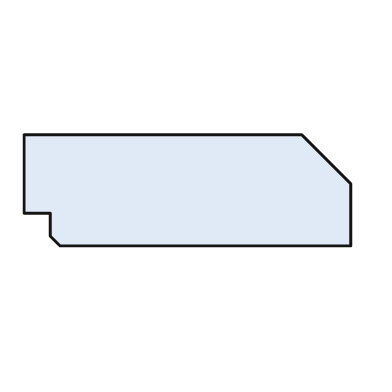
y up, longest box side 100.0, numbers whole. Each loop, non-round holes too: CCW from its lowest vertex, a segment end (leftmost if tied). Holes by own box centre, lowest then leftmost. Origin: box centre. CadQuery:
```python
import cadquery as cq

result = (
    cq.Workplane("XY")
    .moveTo(-39.0, -17.0)
    .lineTo(50.0, -17.0)
    .lineTo(50.0, 2.0)
    .lineTo(35.0, 17.0)
    .lineTo(-50.0, 17.0)
    .lineTo(-50.0, -7.0)
    .lineTo(-42.0, -7.0)
    .lineTo(-42.0, -14.0)
    .close()
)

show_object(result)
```